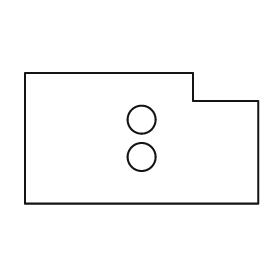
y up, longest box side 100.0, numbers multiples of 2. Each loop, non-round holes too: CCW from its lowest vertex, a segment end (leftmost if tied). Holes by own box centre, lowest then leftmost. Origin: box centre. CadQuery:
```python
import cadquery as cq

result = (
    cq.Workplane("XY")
    .moveTo(-50.0, -28.0)
    .lineTo(50.0, -28.0)
    .lineTo(50.0, 16.0)
    .lineTo(22.0, 16.0)
    .lineTo(22.0, 28.0)
    .lineTo(-50.0, 28.0)
    .close()
    .moveTo(0.0, -8.0)
    .circle(6.0)
    .moveTo(0.0, 8.0)
    .circle(6.0)
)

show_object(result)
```